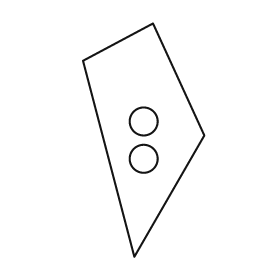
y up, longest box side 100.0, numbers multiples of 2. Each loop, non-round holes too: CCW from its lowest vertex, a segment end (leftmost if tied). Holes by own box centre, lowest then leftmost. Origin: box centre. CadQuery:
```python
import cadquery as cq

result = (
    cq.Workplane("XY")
    .moveTo(-4.0, -50.0)
    .lineTo(26.0, 2.0)
    .lineTo(4.0, 50.0)
    .lineTo(-26.0, 34.0)
    .close()
    .moveTo(0.0, -8.0)
    .circle(6.0)
    .moveTo(0.0, 8.0)
    .circle(6.0)
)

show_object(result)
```